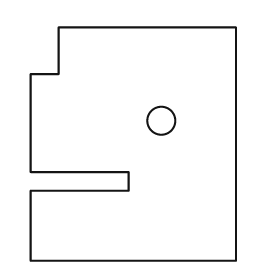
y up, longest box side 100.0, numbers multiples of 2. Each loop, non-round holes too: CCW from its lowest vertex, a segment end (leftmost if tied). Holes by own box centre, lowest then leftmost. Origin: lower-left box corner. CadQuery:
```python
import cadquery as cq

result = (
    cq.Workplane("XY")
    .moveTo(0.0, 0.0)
    .lineTo(88.0, 0.0)
    .lineTo(88.0, 100.0)
    .lineTo(12.0, 100.0)
    .lineTo(12.0, 80.0)
    .lineTo(0.0, 80.0)
    .lineTo(0.0, 38.0)
    .lineTo(42.0, 38.0)
    .lineTo(42.0, 30.0)
    .lineTo(0.0, 30.0)
    .close()
    .moveTo(56.0, 60.0)
    .circle(6.0)
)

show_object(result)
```